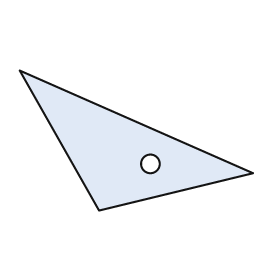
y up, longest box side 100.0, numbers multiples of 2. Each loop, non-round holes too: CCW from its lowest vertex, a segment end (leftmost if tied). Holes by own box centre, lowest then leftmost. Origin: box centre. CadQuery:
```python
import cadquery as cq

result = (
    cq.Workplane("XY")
    .moveTo(-16.0, -30.0)
    .lineTo(50.0, -14.0)
    .lineTo(-50.0, 30.0)
    .close()
    .moveTo(6.0, -10.0)
    .circle(4.0)
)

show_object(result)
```